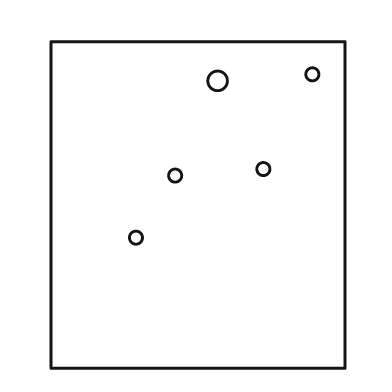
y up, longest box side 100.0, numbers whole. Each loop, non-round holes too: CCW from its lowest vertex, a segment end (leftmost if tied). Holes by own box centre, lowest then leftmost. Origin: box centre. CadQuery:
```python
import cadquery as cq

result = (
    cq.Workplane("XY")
    .moveTo(-45.0, -50.0)
    .lineTo(45.0, -50.0)
    .lineTo(45.0, 50.0)
    .lineTo(-45.0, 50.0)
    .close()
    .moveTo(-19.0, -10.0)
    .circle(2.0)
    .moveTo(-7.0, 9.0)
    .circle(2.0)
    .moveTo(20.0, 11.0)
    .circle(2.0)
    .moveTo(6.0, 38.0)
    .circle(3.0)
    .moveTo(35.0, 40.0)
    .circle(2.0)
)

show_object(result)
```